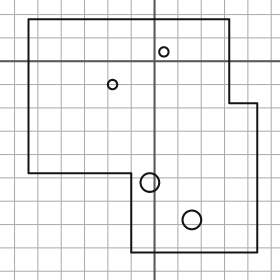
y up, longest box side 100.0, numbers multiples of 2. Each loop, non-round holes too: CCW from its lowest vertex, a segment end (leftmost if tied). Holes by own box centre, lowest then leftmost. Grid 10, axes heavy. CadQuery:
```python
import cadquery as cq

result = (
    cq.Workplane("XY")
    .moveTo(-10.0, -82.0)
    .lineTo(44.0, -82.0)
    .lineTo(44.0, -18.0)
    .lineTo(32.0, -18.0)
    .lineTo(32.0, 18.0)
    .lineTo(-54.0, 18.0)
    .lineTo(-54.0, -48.0)
    .lineTo(-10.0, -48.0)
    .close()
    .moveTo(16.0, -68.0)
    .circle(4.0)
    .moveTo(-2.0, -52.0)
    .circle(4.0)
    .moveTo(-18.0, -10.0)
    .circle(2.0)
    .moveTo(4.0, 4.0)
    .circle(2.0)
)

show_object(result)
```